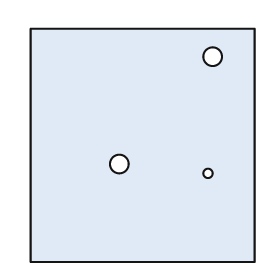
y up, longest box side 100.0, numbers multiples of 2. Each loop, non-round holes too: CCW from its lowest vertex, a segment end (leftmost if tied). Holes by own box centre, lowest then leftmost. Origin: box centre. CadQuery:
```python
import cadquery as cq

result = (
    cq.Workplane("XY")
    .moveTo(-48.0, -50.0)
    .lineTo(48.0, -50.0)
    .lineTo(48.0, 50.0)
    .lineTo(-48.0, 50.0)
    .close()
    .moveTo(28.0, -12.0)
    .circle(2.0)
    .moveTo(-10.0, -8.0)
    .circle(4.0)
    .moveTo(30.0, 38.0)
    .circle(4.0)
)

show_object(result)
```